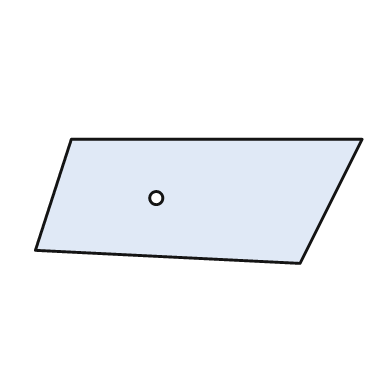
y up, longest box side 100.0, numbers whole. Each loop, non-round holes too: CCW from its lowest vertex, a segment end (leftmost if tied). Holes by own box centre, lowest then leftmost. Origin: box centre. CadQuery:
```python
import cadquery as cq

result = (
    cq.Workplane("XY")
    .moveTo(31.0, -19.0)
    .lineTo(50.0, 19.0)
    .lineTo(-39.0, 19.0)
    .lineTo(-50.0, -15.0)
    .close()
    .moveTo(-13.0, 1.0)
    .circle(2.0)
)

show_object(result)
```